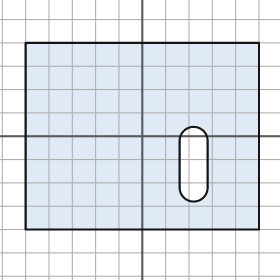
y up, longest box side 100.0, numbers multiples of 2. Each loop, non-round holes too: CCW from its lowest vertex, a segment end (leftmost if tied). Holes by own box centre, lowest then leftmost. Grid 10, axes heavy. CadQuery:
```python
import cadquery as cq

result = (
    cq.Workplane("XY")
    .moveTo(-50.0, -40.0)
    .lineTo(50.0, -40.0)
    .lineTo(50.0, 40.0)
    .lineTo(-50.0, 40.0)
    .close()
    .moveTo(16.0, -22.0)
    .threePointArc((22.0, -28.0), (28.0, -22.0))
    .lineTo(28.0, -2.0)
    .threePointArc((22.0, 4.0), (16.0, -2.0))
    .close()
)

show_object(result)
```